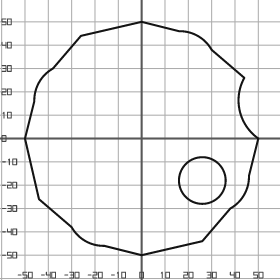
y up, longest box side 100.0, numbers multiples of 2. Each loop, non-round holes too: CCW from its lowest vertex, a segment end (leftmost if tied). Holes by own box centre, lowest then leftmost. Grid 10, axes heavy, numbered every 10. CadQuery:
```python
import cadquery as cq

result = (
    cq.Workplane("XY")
    .moveTo(0.0, -50.0)
    .lineTo(26.0, -44.0)
    .lineTo(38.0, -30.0)
    .threePointArc((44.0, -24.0), (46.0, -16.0))
    .lineTo(50.0, 0.0)
    .threePointArc((42.0, 12.0), (44.0, 26.0))
    .lineTo(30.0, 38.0)
    .threePointArc((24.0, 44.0), (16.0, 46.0))
    .lineTo(0.0, 50.0)
    .lineTo(-26.0, 44.0)
    .lineTo(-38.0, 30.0)
    .threePointArc((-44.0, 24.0), (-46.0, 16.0))
    .lineTo(-50.0, 0.0)
    .lineTo(-44.0, -26.0)
    .lineTo(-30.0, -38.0)
    .threePointArc((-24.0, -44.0), (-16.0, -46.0))
    .close()
    .moveTo(26.0, -18.0)
    .circle(10.0)
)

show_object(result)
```